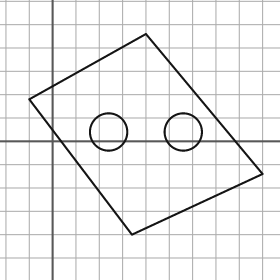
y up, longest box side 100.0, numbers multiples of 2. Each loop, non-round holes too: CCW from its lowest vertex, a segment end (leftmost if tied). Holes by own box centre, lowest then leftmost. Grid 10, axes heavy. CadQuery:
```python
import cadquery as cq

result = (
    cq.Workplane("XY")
    .moveTo(34.0, -40.0)
    .lineTo(90.0, -14.0)
    .lineTo(40.0, 46.0)
    .lineTo(-10.0, 18.0)
    .close()
    .moveTo(24.0, 4.0)
    .circle(8.0)
    .moveTo(56.0, 4.0)
    .circle(8.0)
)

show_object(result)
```